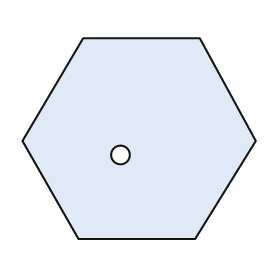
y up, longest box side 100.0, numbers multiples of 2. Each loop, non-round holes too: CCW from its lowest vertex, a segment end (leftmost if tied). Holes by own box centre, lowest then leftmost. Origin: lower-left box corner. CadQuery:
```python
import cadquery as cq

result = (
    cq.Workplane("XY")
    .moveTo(24.0, 0.0)
    .lineTo(74.0, 0.0)
    .lineTo(100.0, 42.0)
    .lineTo(76.0, 86.0)
    .lineTo(26.0, 86.0)
    .lineTo(0.0, 42.0)
    .close()
    .moveTo(42.0, 36.0)
    .circle(4.0)
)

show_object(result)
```